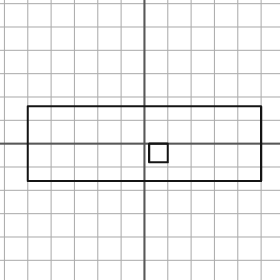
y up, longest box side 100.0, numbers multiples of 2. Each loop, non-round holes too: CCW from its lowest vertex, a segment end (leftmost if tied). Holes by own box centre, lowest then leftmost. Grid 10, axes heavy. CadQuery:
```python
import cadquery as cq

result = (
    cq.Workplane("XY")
    .moveTo(-50.0, -16.0)
    .lineTo(50.0, -16.0)
    .lineTo(50.0, 16.0)
    .lineTo(-50.0, 16.0)
    .close()
    .moveTo(2.0, -8.0)
    .lineTo(10.0, -8.0)
    .lineTo(10.0, 0.0)
    .lineTo(2.0, 0.0)
    .close()
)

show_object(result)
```